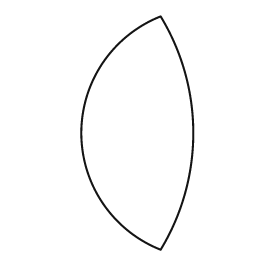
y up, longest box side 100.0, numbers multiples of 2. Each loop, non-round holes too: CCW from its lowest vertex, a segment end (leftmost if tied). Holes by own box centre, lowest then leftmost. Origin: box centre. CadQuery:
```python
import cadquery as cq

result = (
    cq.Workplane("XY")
    .moveTo(10.0, -50.0)
    .threePointArc((24.0, 0.0), (10.0, 50.0))
    .threePointArc((-24.0, 0.0), (10.0, -50.0))
    .close()
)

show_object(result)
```